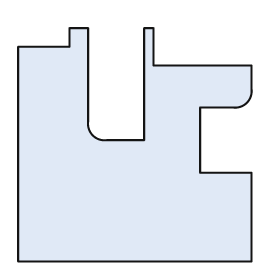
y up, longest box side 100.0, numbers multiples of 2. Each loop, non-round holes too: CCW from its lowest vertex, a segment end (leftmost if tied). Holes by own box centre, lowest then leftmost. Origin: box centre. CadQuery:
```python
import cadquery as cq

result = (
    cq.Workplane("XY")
    .moveTo(-50.0, -50.0)
    .lineTo(50.0, -50.0)
    .lineTo(50.0, -12.0)
    .lineTo(28.0, -12.0)
    .lineTo(28.0, 16.0)
    .lineTo(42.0, 16.0)
    .threePointArc((48.0, 18.0), (50.0, 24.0))
    .lineTo(50.0, 34.0)
    .lineTo(8.0, 34.0)
    .lineTo(8.0, 50.0)
    .lineTo(4.0, 50.0)
    .lineTo(4.0, 2.0)
    .lineTo(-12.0, 2.0)
    .threePointArc((-18.0, 4.0), (-20.0, 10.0))
    .lineTo(-20.0, 50.0)
    .lineTo(-28.0, 50.0)
    .lineTo(-28.0, 42.0)
    .lineTo(-50.0, 42.0)
    .close()
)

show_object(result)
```